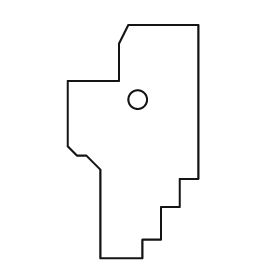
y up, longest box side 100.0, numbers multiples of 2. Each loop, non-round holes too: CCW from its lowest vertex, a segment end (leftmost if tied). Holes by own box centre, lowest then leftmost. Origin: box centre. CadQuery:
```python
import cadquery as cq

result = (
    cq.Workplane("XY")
    .moveTo(-14.0, -50.0)
    .lineTo(4.0, -50.0)
    .lineTo(4.0, -42.0)
    .lineTo(12.0, -42.0)
    .lineTo(12.0, -28.0)
    .lineTo(20.0, -28.0)
    .lineTo(20.0, -16.0)
    .lineTo(28.0, -16.0)
    .lineTo(28.0, 50.0)
    .lineTo(-2.0, 50.0)
    .lineTo(-6.0, 42.0)
    .lineTo(-6.0, 26.0)
    .lineTo(-28.0, 26.0)
    .lineTo(-28.0, -2.0)
    .lineTo(-24.0, -6.0)
    .lineTo(-20.0, -6.0)
    .lineTo(-14.0, -12.0)
    .close()
    .moveTo(2.0, 18.0)
    .circle(4.0)
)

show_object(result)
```